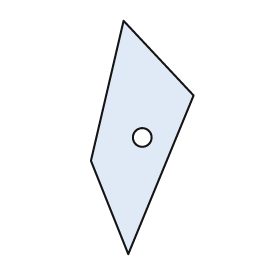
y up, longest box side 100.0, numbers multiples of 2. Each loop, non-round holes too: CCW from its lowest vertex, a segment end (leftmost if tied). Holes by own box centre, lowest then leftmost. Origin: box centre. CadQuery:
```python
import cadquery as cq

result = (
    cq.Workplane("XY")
    .moveTo(-6.0, -50.0)
    .lineTo(22.0, 18.0)
    .lineTo(-8.0, 50.0)
    .lineTo(-22.0, -10.0)
    .close()
    .moveTo(0.0, 0.0)
    .circle(4.0)
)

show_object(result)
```